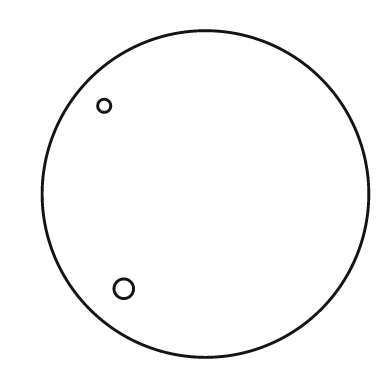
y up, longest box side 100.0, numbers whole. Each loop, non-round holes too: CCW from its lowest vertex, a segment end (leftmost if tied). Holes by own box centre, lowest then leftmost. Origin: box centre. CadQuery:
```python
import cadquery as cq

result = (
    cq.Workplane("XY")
    .moveTo(0.0, 0.0)
    .circle(50.0)
    .moveTo(-25.0, -29.0)
    .circle(3.0)
    .moveTo(-31.0, 27.0)
    .circle(2.0)
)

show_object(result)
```